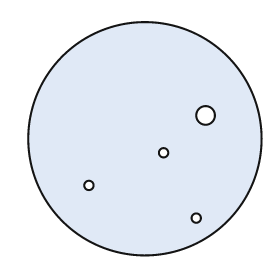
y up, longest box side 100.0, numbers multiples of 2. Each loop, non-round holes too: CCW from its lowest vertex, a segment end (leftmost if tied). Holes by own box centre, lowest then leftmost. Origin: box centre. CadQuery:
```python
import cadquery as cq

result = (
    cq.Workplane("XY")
    .moveTo(0.0, 0.0)
    .circle(50.0)
    .moveTo(22.0, -34.0)
    .circle(2.0)
    .moveTo(-24.0, -20.0)
    .circle(2.0)
    .moveTo(8.0, -6.0)
    .circle(2.0)
    .moveTo(26.0, 10.0)
    .circle(4.0)
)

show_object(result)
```